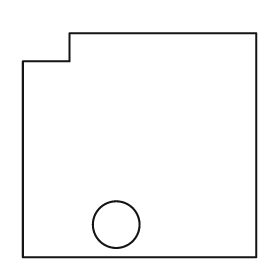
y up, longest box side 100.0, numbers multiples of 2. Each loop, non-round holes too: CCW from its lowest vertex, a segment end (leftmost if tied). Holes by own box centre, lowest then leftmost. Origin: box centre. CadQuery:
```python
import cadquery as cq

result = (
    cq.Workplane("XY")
    .moveTo(-50.0, -48.0)
    .lineTo(50.0, -48.0)
    .lineTo(50.0, 48.0)
    .lineTo(-30.0, 48.0)
    .lineTo(-30.0, 36.0)
    .lineTo(-50.0, 36.0)
    .close()
    .moveTo(-10.0, -34.0)
    .circle(10.0)
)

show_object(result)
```